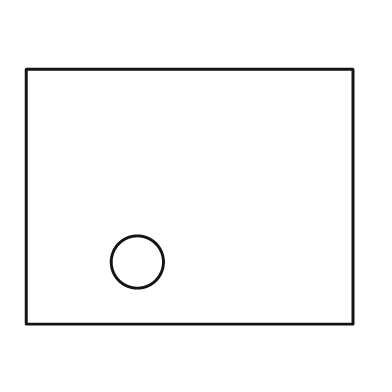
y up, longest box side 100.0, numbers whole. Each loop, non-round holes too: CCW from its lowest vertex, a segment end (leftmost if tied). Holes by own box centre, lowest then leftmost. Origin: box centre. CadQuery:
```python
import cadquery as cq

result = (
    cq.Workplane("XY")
    .moveTo(-50.0, -39.0)
    .lineTo(50.0, -39.0)
    .lineTo(50.0, 39.0)
    .lineTo(-50.0, 39.0)
    .close()
    .moveTo(-16.0, -20.0)
    .circle(8.0)
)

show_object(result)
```